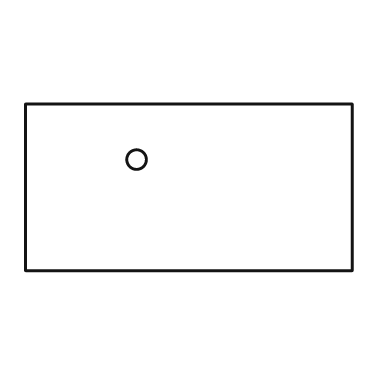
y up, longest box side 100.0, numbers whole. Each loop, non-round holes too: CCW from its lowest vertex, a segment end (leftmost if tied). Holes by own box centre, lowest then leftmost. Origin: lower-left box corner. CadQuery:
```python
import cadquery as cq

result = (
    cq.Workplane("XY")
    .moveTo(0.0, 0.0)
    .lineTo(100.0, 0.0)
    .lineTo(100.0, 51.0)
    .lineTo(0.0, 51.0)
    .close()
    .moveTo(34.0, 34.0)
    .circle(3.0)
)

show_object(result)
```